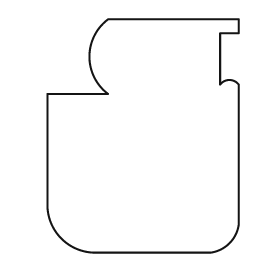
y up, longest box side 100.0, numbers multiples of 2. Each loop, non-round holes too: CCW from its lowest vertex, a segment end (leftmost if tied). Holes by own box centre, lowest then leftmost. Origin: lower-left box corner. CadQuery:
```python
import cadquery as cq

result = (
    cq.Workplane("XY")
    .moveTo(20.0, 0.0)
    .lineTo(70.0, 0.0)
    .threePointArc((78.0, 4.0), (82.0, 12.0))
    .lineTo(82.0, 72.0)
    .threePointArc((78.0, 74.0), (74.0, 72.0))
    .lineTo(74.0, 94.0)
    .lineTo(82.0, 94.0)
    .lineTo(82.0, 100.0)
    .lineTo(26.0, 100.0)
    .threePointArc((18.0, 84.0), (26.0, 68.0))
    .lineTo(0.0, 68.0)
    .lineTo(0.0, 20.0)
    .threePointArc((6.0, 6.0), (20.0, 0.0))
    .close()
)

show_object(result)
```